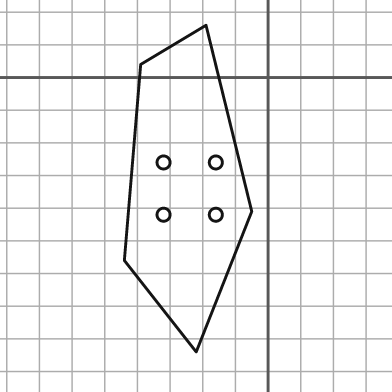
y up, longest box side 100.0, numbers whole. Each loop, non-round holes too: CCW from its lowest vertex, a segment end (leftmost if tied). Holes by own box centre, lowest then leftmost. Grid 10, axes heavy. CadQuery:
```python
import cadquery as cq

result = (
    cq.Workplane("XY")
    .moveTo(-22.0, -84.0)
    .lineTo(-5.0, -41.0)
    .lineTo(-19.0, 16.0)
    .lineTo(-39.0, 4.0)
    .lineTo(-44.0, -56.0)
    .close()
    .moveTo(-32.0, -42.0)
    .circle(2.0)
    .moveTo(-16.0, -42.0)
    .circle(2.0)
    .moveTo(-32.0, -26.0)
    .circle(2.0)
    .moveTo(-16.0, -26.0)
    .circle(2.0)
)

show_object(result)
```